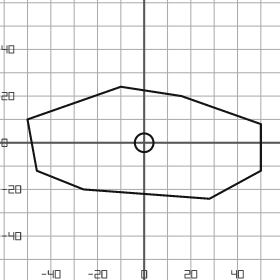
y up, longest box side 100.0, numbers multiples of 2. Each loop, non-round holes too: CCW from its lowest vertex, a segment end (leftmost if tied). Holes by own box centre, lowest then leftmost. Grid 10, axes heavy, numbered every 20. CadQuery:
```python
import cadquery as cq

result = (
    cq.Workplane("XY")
    .moveTo(28.0, -24.0)
    .lineTo(50.0, -12.0)
    .lineTo(50.0, 8.0)
    .lineTo(16.0, 20.0)
    .lineTo(-10.0, 24.0)
    .lineTo(-50.0, 10.0)
    .lineTo(-46.0, -12.0)
    .lineTo(-26.0, -20.0)
    .close()
    .moveTo(0.0, 0.0)
    .circle(4.0)
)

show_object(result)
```